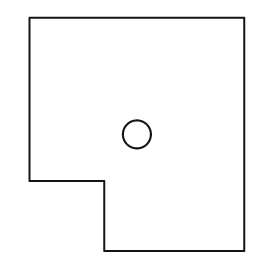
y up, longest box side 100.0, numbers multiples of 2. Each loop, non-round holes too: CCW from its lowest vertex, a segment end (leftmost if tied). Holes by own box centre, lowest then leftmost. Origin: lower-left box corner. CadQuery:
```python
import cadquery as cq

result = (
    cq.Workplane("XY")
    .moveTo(32.0, 0.0)
    .lineTo(92.0, 0.0)
    .lineTo(92.0, 100.0)
    .lineTo(0.0, 100.0)
    .lineTo(0.0, 30.0)
    .lineTo(32.0, 30.0)
    .close()
    .moveTo(46.0, 50.0)
    .circle(6.0)
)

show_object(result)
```